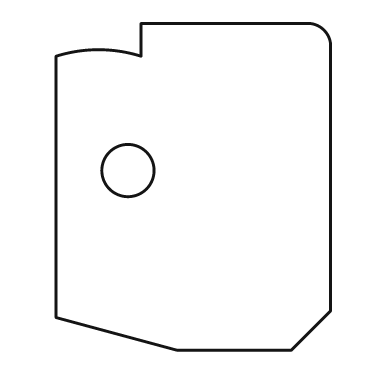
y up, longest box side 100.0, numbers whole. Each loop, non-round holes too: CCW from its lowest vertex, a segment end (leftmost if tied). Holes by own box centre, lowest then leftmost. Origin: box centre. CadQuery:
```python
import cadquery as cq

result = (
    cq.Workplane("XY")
    .moveTo(-5.0, -50.0)
    .lineTo(30.0, -50.0)
    .lineTo(42.0, -38.0)
    .lineTo(42.0, 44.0)
    .threePointArc((40.0, 48.0), (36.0, 50.0))
    .lineTo(-16.0, 50.0)
    .lineTo(-16.0, 40.0)
    .threePointArc((-29.0, 42.0), (-42.0, 40.0))
    .lineTo(-42.0, -40.0)
    .close()
    .moveTo(-20.0, 5.0)
    .circle(8.0)
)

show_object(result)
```